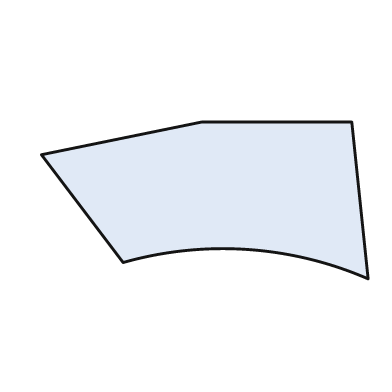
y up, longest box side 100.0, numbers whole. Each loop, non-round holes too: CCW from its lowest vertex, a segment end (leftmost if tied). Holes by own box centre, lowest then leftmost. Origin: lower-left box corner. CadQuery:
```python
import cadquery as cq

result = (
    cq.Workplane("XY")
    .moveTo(100.0, 0.0)
    .lineTo(95.0, 48.0)
    .lineTo(49.0, 48.0)
    .lineTo(0.0, 38.0)
    .lineTo(25.0, 5.0)
    .threePointArc((63.0, 9.0), (100.0, 0.0))
    .close()
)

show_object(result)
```